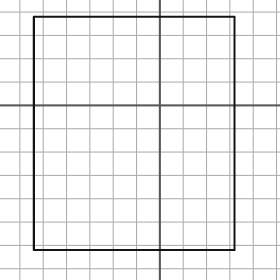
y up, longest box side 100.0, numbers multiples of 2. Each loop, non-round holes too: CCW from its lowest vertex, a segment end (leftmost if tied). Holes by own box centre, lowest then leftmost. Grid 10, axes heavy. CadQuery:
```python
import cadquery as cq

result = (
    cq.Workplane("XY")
    .moveTo(-54.0, -62.0)
    .lineTo(32.0, -62.0)
    .lineTo(32.0, 38.0)
    .lineTo(-54.0, 38.0)
    .close()
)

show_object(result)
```